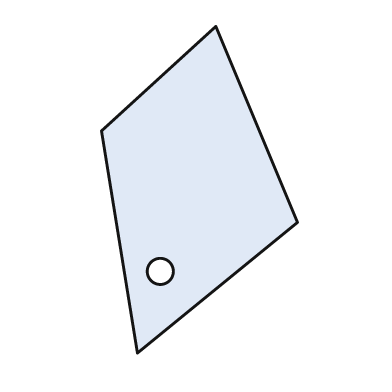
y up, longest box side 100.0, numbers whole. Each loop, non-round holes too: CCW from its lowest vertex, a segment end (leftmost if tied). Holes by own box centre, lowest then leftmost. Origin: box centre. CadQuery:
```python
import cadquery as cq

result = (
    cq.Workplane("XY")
    .moveTo(-19.0, -50.0)
    .lineTo(30.0, -10.0)
    .lineTo(5.0, 50.0)
    .lineTo(-30.0, 18.0)
    .close()
    .moveTo(-12.0, -25.0)
    .circle(4.0)
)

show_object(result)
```